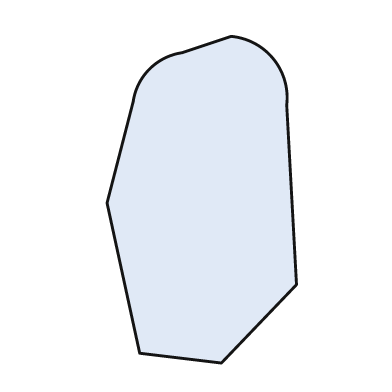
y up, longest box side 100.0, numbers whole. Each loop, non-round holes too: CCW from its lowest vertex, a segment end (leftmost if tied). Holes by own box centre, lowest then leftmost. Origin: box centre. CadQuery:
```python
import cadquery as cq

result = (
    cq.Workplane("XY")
    .moveTo(6.0, -50.0)
    .lineTo(29.0, -26.0)
    .lineTo(26.0, 29.0)
    .threePointArc((22.0, 43.0), (9.0, 50.0))
    .lineTo(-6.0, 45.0)
    .threePointArc((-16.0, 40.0), (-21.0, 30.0))
    .lineTo(-29.0, -1.0)
    .lineTo(-19.0, -47.0)
    .close()
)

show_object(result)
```